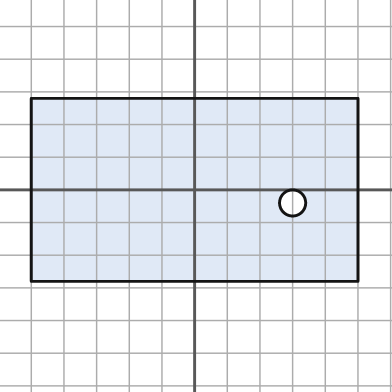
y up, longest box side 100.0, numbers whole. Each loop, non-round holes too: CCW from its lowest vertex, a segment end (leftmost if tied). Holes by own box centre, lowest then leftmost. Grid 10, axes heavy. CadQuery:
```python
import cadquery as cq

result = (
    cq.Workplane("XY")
    .moveTo(-50.0, -28.0)
    .lineTo(50.0, -28.0)
    .lineTo(50.0, 28.0)
    .lineTo(-50.0, 28.0)
    .close()
    .moveTo(30.0, -4.0)
    .circle(4.0)
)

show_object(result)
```